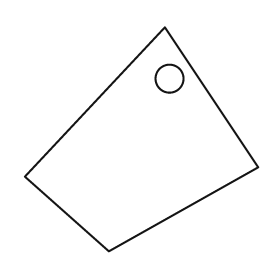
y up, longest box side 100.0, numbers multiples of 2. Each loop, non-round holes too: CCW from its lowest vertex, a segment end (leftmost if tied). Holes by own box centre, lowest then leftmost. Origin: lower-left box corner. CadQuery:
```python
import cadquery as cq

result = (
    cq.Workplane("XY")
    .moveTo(36.0, 0.0)
    .lineTo(100.0, 36.0)
    .lineTo(60.0, 96.0)
    .lineTo(0.0, 32.0)
    .close()
    .moveTo(62.0, 74.0)
    .circle(6.0)
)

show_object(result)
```